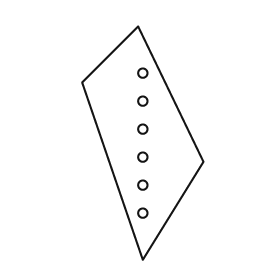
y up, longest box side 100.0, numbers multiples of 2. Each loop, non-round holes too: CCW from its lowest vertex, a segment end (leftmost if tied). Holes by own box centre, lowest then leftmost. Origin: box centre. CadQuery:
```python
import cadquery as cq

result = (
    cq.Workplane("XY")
    .moveTo(0.0, -50.0)
    .lineTo(26.0, -8.0)
    .lineTo(-2.0, 50.0)
    .lineTo(-26.0, 26.0)
    .close()
    .moveTo(0.0, -30.0)
    .circle(2.0)
    .moveTo(0.0, -18.0)
    .circle(2.0)
    .moveTo(0.0, -6.0)
    .circle(2.0)
    .moveTo(0.0, 6.0)
    .circle(2.0)
    .moveTo(0.0, 18.0)
    .circle(2.0)
    .moveTo(0.0, 30.0)
    .circle(2.0)
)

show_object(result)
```